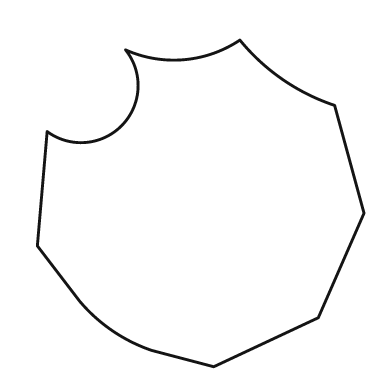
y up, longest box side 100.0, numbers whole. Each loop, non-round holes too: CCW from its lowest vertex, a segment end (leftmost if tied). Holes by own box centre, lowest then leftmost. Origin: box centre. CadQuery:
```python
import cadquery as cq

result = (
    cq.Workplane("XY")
    .moveTo(4.0, -50.0)
    .lineTo(36.0, -35.0)
    .lineTo(50.0, -3.0)
    .lineTo(41.0, 30.0)
    .threePointArc((25.0, 38.0), (12.0, 50.0))
    .threePointArc((-5.0, 44.0), (-23.0, 47.0))
    .threePointArc((-24.0, 24.0), (-47.0, 22.0))
    .lineTo(-50.0, -13.0)
    .lineTo(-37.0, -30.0)
    .threePointArc((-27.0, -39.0), (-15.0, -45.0))
    .close()
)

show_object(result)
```